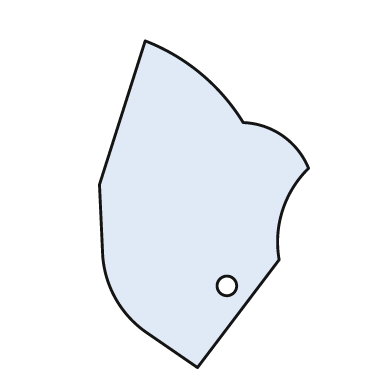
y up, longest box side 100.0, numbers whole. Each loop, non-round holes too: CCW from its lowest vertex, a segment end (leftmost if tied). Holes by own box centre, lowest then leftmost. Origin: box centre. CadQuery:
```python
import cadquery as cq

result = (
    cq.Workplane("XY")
    .moveTo(-2.0, -50.0)
    .lineTo(23.0, -17.0)
    .threePointArc((24.0, -2.0), (32.0, 11.0))
    .threePointArc((24.0, 21.0), (12.0, 25.0))
    .threePointArc((-1.0, 40.0), (-18.0, 50.0))
    .lineTo(-32.0, 6.0)
    .lineTo(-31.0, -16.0)
    .threePointArc((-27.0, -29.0), (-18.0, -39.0))
    .close()
    .moveTo(7.0, -25.0)
    .circle(3.0)
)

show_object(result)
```